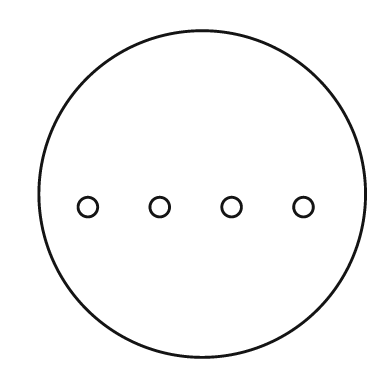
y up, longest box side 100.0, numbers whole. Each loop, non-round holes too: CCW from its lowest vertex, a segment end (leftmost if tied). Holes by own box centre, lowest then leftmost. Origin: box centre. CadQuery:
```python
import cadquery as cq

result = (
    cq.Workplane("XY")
    .moveTo(0.0, 0.0)
    .circle(50.0)
    .moveTo(-35.0, -4.0)
    .circle(3.0)
    .moveTo(-13.0, -4.0)
    .circle(3.0)
    .moveTo(9.0, -4.0)
    .circle(3.0)
    .moveTo(31.0, -4.0)
    .circle(3.0)
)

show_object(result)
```